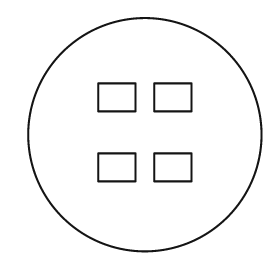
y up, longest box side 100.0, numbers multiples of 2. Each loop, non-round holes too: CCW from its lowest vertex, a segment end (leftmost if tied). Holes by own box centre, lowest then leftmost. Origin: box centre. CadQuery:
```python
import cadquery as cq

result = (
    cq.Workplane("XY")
    .moveTo(0.0, 0.0)
    .circle(50.0)
    .moveTo(-20.0, -20.0)
    .lineTo(-4.0, -20.0)
    .lineTo(-4.0, -8.0)
    .lineTo(-20.0, -8.0)
    .close()
    .moveTo(4.0, -20.0)
    .lineTo(20.0, -20.0)
    .lineTo(20.0, -8.0)
    .lineTo(4.0, -8.0)
    .close()
    .moveTo(-20.0, 10.0)
    .lineTo(-4.0, 10.0)
    .lineTo(-4.0, 22.0)
    .lineTo(-20.0, 22.0)
    .close()
    .moveTo(4.0, 10.0)
    .lineTo(20.0, 10.0)
    .lineTo(20.0, 22.0)
    .lineTo(4.0, 22.0)
    .close()
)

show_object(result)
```